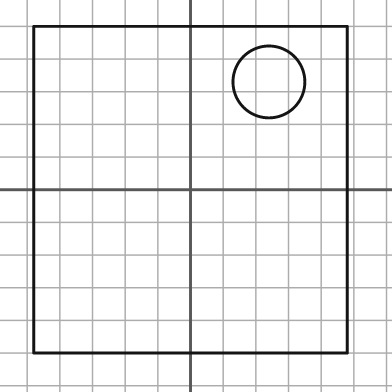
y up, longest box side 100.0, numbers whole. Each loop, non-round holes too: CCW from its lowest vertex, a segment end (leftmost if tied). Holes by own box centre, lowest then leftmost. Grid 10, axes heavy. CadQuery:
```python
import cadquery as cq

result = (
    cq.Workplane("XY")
    .moveTo(-48.0, -50.0)
    .lineTo(48.0, -50.0)
    .lineTo(48.0, 50.0)
    .lineTo(-48.0, 50.0)
    .close()
    .moveTo(24.0, 33.0)
    .circle(11.0)
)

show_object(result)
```